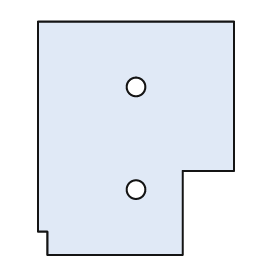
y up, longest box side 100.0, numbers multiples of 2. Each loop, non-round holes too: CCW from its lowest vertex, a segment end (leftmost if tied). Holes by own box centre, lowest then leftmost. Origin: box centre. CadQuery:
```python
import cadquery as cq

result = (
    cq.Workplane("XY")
    .moveTo(-38.0, -50.0)
    .lineTo(20.0, -50.0)
    .lineTo(20.0, -14.0)
    .lineTo(42.0, -14.0)
    .lineTo(42.0, 50.0)
    .lineTo(-42.0, 50.0)
    .lineTo(-42.0, -40.0)
    .lineTo(-38.0, -40.0)
    .close()
    .moveTo(0.0, -22.0)
    .circle(4.0)
    .moveTo(0.0, 22.0)
    .circle(4.0)
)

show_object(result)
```